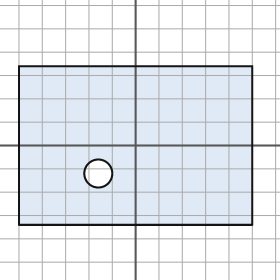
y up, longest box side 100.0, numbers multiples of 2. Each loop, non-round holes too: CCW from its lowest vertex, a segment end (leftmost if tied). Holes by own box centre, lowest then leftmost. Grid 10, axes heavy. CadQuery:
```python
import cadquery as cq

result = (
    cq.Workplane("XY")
    .moveTo(-50.0, -34.0)
    .lineTo(50.0, -34.0)
    .lineTo(50.0, 34.0)
    .lineTo(-50.0, 34.0)
    .close()
    .moveTo(-16.0, -12.0)
    .circle(6.0)
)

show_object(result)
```